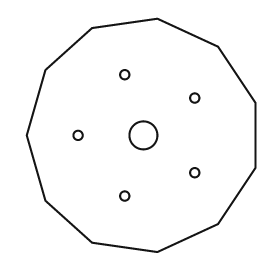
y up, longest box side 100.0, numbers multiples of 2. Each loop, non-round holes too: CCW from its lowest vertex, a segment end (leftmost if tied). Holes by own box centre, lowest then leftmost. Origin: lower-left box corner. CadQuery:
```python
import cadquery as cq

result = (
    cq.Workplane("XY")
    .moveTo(56.0, 0.0)
    .lineTo(82.0, 12.0)
    .lineTo(98.0, 36.0)
    .lineTo(98.0, 64.0)
    .lineTo(82.0, 88.0)
    .lineTo(56.0, 100.0)
    .lineTo(28.0, 96.0)
    .lineTo(8.0, 78.0)
    .lineTo(0.0, 50.0)
    .lineTo(8.0, 22.0)
    .lineTo(28.0, 4.0)
    .close()
    .moveTo(42.0, 24.0)
    .circle(2.0)
    .moveTo(72.0, 34.0)
    .circle(2.0)
    .moveTo(22.0, 50.0)
    .circle(2.0)
    .moveTo(50.0, 50.0)
    .circle(6.0)
    .moveTo(72.0, 66.0)
    .circle(2.0)
    .moveTo(42.0, 76.0)
    .circle(2.0)
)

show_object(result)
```